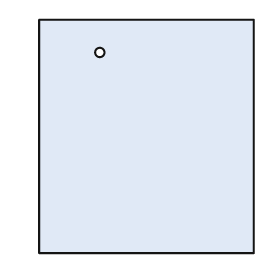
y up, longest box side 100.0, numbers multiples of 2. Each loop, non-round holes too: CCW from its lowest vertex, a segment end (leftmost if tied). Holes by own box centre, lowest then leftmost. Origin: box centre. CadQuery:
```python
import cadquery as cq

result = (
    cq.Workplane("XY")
    .moveTo(-46.0, -50.0)
    .lineTo(46.0, -50.0)
    .lineTo(46.0, 50.0)
    .lineTo(-46.0, 50.0)
    .close()
    .moveTo(-20.0, 36.0)
    .circle(2.0)
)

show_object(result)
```